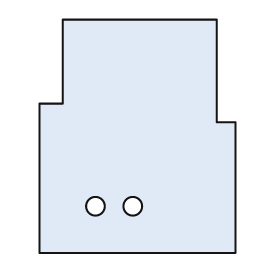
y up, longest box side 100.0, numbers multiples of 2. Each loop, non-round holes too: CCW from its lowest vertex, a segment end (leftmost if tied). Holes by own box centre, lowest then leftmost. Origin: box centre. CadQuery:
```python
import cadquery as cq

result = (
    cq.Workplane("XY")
    .moveTo(-42.0, -50.0)
    .lineTo(42.0, -50.0)
    .lineTo(42.0, 6.0)
    .lineTo(34.0, 6.0)
    .lineTo(34.0, 50.0)
    .lineTo(-32.0, 50.0)
    .lineTo(-32.0, 14.0)
    .lineTo(-42.0, 14.0)
    .close()
    .moveTo(-18.0, -30.0)
    .circle(4.0)
    .moveTo(-2.0, -30.0)
    .circle(4.0)
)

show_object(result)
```